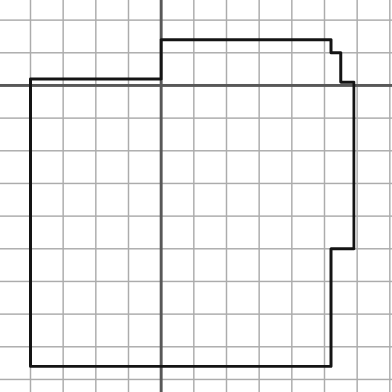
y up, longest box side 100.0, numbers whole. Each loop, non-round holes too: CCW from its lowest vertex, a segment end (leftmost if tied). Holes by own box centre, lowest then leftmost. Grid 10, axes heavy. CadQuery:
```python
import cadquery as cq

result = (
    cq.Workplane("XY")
    .moveTo(-40.0, -86.0)
    .lineTo(52.0, -86.0)
    .lineTo(52.0, -50.0)
    .lineTo(59.0, -50.0)
    .lineTo(59.0, 1.0)
    .lineTo(55.0, 1.0)
    .lineTo(55.0, 10.0)
    .lineTo(52.0, 10.0)
    .lineTo(52.0, 14.0)
    .lineTo(0.0, 14.0)
    .lineTo(0.0, 2.0)
    .lineTo(-40.0, 2.0)
    .close()
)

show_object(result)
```